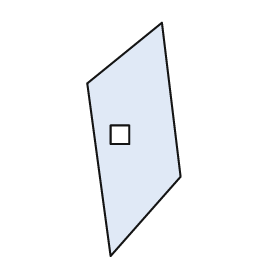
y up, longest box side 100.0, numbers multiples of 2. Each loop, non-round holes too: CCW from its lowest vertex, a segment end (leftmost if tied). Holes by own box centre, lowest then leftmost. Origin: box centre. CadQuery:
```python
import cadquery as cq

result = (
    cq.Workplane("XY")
    .moveTo(-10.0, -50.0)
    .lineTo(20.0, -16.0)
    .lineTo(12.0, 50.0)
    .lineTo(-20.0, 24.0)
    .close()
    .moveTo(-10.0, -2.0)
    .lineTo(-2.0, -2.0)
    .lineTo(-2.0, 6.0)
    .lineTo(-10.0, 6.0)
    .close()
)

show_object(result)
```